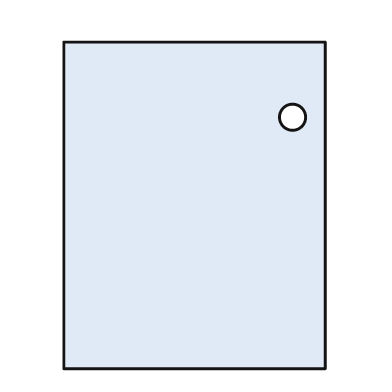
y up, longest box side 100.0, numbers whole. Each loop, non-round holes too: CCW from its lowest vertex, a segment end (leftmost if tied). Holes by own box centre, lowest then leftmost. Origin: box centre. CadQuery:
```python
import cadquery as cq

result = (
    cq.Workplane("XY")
    .moveTo(-40.0, -50.0)
    .lineTo(40.0, -50.0)
    .lineTo(40.0, 50.0)
    .lineTo(-40.0, 50.0)
    .close()
    .moveTo(30.0, 27.0)
    .circle(4.0)
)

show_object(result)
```